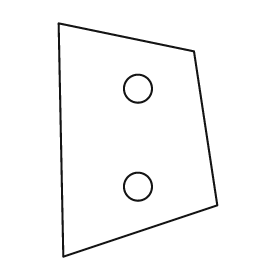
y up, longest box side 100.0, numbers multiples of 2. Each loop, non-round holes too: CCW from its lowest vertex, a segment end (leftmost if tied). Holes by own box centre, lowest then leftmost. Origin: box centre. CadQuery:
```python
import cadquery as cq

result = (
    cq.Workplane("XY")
    .moveTo(-32.0, -50.0)
    .lineTo(34.0, -28.0)
    .lineTo(24.0, 38.0)
    .lineTo(-34.0, 50.0)
    .close()
    .moveTo(0.0, -20.0)
    .circle(6.0)
    .moveTo(0.0, 22.0)
    .circle(6.0)
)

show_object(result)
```